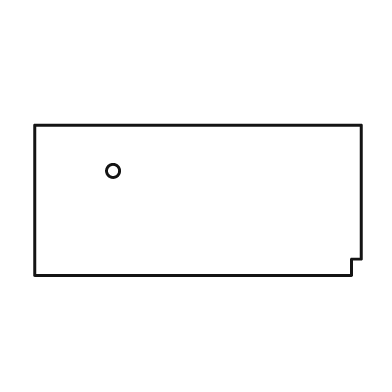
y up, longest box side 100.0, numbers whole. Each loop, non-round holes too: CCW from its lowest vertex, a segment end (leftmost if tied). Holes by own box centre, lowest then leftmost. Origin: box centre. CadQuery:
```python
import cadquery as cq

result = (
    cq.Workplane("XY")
    .moveTo(-50.0, -23.0)
    .lineTo(47.0, -23.0)
    .lineTo(47.0, -18.0)
    .lineTo(50.0, -18.0)
    .lineTo(50.0, 23.0)
    .lineTo(-50.0, 23.0)
    .close()
    .moveTo(-26.0, 9.0)
    .circle(2.0)
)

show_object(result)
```